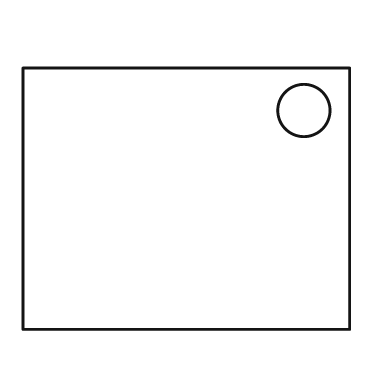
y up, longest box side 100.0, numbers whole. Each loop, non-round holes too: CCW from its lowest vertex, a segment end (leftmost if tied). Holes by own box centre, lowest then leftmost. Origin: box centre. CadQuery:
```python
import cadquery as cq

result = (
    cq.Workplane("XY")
    .moveTo(-50.0, -40.0)
    .lineTo(50.0, -40.0)
    .lineTo(50.0, 40.0)
    .lineTo(-50.0, 40.0)
    .close()
    .moveTo(36.0, 27.0)
    .circle(8.0)
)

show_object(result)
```